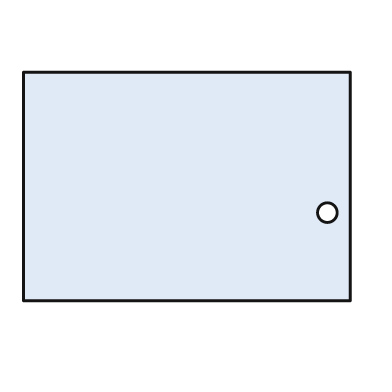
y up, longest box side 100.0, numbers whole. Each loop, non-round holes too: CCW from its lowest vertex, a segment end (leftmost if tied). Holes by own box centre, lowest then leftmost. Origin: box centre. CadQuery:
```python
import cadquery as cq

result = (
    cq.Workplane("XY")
    .moveTo(-50.0, -35.0)
    .lineTo(50.0, -35.0)
    .lineTo(50.0, 35.0)
    .lineTo(-50.0, 35.0)
    .close()
    .moveTo(43.0, -8.0)
    .circle(3.0)
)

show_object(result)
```